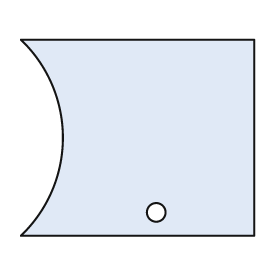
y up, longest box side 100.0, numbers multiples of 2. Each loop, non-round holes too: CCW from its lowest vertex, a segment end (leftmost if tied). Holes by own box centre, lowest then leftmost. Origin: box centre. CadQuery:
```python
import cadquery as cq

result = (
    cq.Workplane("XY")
    .moveTo(-50.0, -42.0)
    .lineTo(50.0, -42.0)
    .lineTo(50.0, 42.0)
    .lineTo(-50.0, 42.0)
    .threePointArc((-32.0, 0.0), (-50.0, -42.0))
    .close()
    .moveTo(8.0, -32.0)
    .circle(4.0)
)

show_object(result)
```